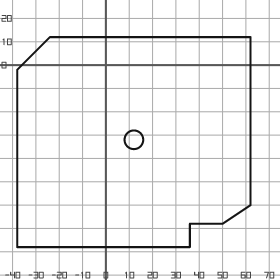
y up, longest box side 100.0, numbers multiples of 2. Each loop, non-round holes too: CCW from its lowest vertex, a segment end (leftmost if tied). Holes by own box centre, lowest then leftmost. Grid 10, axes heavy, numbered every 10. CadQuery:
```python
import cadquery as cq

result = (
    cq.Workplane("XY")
    .moveTo(-38.0, -78.0)
    .lineTo(36.0, -78.0)
    .lineTo(36.0, -68.0)
    .lineTo(50.0, -68.0)
    .lineTo(62.0, -60.0)
    .lineTo(62.0, 12.0)
    .lineTo(-24.0, 12.0)
    .lineTo(-38.0, -2.0)
    .close()
    .moveTo(12.0, -32.0)
    .circle(4.0)
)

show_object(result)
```